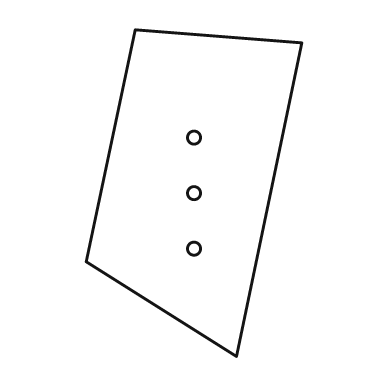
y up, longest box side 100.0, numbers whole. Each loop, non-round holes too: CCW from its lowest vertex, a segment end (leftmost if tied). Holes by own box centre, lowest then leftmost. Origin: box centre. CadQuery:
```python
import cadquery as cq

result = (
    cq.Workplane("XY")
    .moveTo(13.0, -50.0)
    .lineTo(33.0, 46.0)
    .lineTo(-18.0, 50.0)
    .lineTo(-33.0, -21.0)
    .close()
    .moveTo(0.0, -17.0)
    .circle(2.0)
    .moveTo(0.0, 0.0)
    .circle(2.0)
    .moveTo(0.0, 17.0)
    .circle(2.0)
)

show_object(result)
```